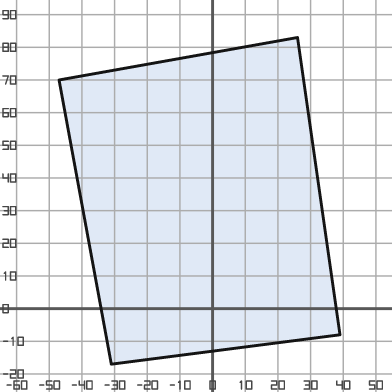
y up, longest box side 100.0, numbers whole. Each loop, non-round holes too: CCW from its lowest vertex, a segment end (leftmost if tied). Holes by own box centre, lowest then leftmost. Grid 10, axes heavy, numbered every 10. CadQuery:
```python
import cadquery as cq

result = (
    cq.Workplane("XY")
    .moveTo(-31.0, -17.0)
    .lineTo(39.0, -8.0)
    .lineTo(26.0, 83.0)
    .lineTo(-47.0, 70.0)
    .close()
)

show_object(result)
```